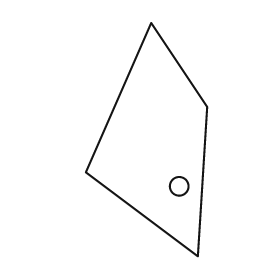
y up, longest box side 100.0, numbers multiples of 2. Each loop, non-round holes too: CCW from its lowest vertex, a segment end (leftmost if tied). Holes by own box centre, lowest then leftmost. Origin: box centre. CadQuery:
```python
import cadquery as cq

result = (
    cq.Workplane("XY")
    .moveTo(22.0, -50.0)
    .lineTo(26.0, 14.0)
    .lineTo(2.0, 50.0)
    .lineTo(-26.0, -14.0)
    .close()
    .moveTo(14.0, -20.0)
    .circle(4.0)
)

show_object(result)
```